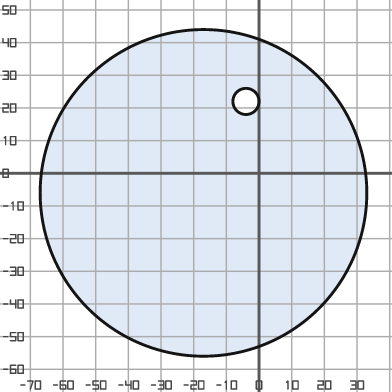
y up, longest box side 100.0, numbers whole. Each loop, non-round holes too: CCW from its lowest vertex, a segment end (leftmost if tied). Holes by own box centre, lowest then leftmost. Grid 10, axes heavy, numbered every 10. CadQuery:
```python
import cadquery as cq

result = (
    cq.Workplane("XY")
    .moveTo(-17.0, -6.0)
    .circle(50.0)
    .moveTo(-4.0, 22.0)
    .circle(4.0)
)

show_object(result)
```